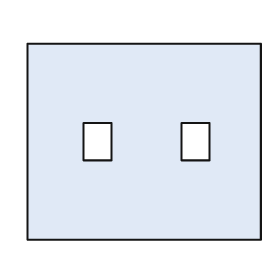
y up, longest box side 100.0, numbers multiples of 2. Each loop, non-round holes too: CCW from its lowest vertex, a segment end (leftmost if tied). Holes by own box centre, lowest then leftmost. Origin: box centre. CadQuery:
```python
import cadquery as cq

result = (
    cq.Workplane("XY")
    .moveTo(-50.0, -42.0)
    .lineTo(50.0, -42.0)
    .lineTo(50.0, 42.0)
    .lineTo(-50.0, 42.0)
    .close()
    .moveTo(-26.0, -8.0)
    .lineTo(-14.0, -8.0)
    .lineTo(-14.0, 8.0)
    .lineTo(-26.0, 8.0)
    .close()
    .moveTo(16.0, -8.0)
    .lineTo(28.0, -8.0)
    .lineTo(28.0, 8.0)
    .lineTo(16.0, 8.0)
    .close()
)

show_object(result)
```